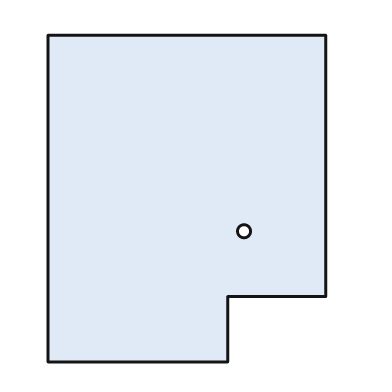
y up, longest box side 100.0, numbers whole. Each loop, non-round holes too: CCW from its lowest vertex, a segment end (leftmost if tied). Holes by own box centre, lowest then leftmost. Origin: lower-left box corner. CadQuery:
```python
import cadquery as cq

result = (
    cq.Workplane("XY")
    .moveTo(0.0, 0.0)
    .lineTo(55.0, 0.0)
    .lineTo(55.0, 20.0)
    .lineTo(85.0, 20.0)
    .lineTo(85.0, 100.0)
    .lineTo(0.0, 100.0)
    .close()
    .moveTo(60.0, 40.0)
    .circle(2.0)
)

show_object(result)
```